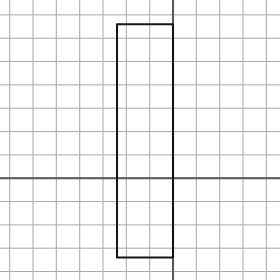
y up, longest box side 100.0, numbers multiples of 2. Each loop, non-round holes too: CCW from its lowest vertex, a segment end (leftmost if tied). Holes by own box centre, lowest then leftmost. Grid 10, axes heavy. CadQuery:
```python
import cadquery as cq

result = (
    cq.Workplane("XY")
    .moveTo(-24.0, -34.0)
    .lineTo(0.0, -34.0)
    .lineTo(0.0, 66.0)
    .lineTo(-24.0, 66.0)
    .close()
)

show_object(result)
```